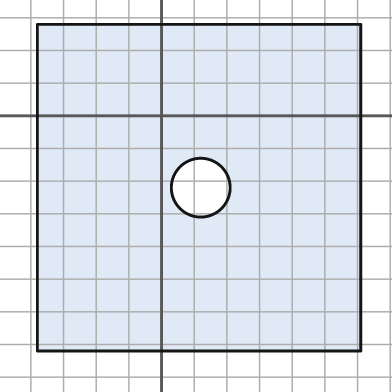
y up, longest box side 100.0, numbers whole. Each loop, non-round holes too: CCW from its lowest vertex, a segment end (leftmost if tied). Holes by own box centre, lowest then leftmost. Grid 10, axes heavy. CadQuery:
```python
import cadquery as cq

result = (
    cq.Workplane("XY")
    .moveTo(-38.0, -72.0)
    .lineTo(61.0, -72.0)
    .lineTo(61.0, 28.0)
    .lineTo(-38.0, 28.0)
    .close()
    .moveTo(12.0, -22.0)
    .circle(9.0)
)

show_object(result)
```